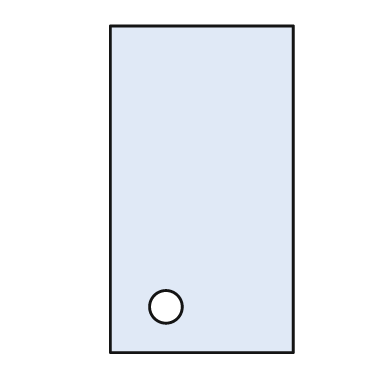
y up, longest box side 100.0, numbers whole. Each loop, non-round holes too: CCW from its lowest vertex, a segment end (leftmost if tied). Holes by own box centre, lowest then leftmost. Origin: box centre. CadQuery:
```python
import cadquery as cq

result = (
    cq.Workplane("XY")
    .moveTo(-28.0, -50.0)
    .lineTo(28.0, -50.0)
    .lineTo(28.0, 50.0)
    .lineTo(-28.0, 50.0)
    .close()
    .moveTo(-11.0, -36.0)
    .circle(5.0)
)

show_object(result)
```